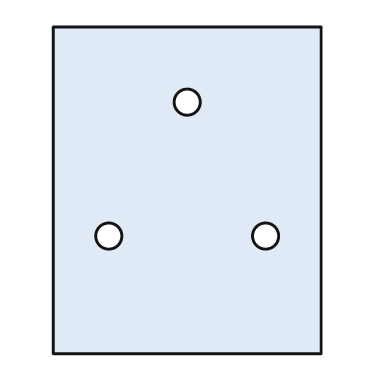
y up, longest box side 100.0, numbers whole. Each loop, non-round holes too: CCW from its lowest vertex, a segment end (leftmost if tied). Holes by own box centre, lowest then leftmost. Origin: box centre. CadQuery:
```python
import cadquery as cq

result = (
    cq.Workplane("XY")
    .moveTo(-41.0, -50.0)
    .lineTo(41.0, -50.0)
    .lineTo(41.0, 50.0)
    .lineTo(-41.0, 50.0)
    .close()
    .moveTo(-24.0, -14.0)
    .circle(4.0)
    .moveTo(24.0, -14.0)
    .circle(4.0)
    .moveTo(0.0, 27.0)
    .circle(4.0)
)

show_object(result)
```